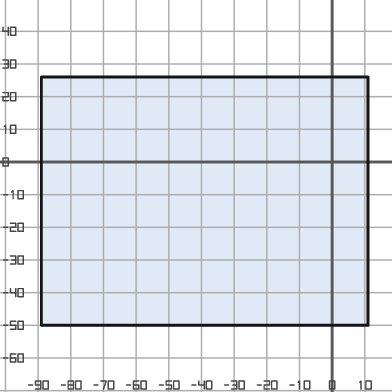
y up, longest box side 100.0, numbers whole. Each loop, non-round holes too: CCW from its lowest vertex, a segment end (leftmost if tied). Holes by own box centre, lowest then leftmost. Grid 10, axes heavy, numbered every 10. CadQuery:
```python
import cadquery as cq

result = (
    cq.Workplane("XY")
    .moveTo(-89.0, -50.0)
    .lineTo(11.0, -50.0)
    .lineTo(11.0, 26.0)
    .lineTo(-89.0, 26.0)
    .close()
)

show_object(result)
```